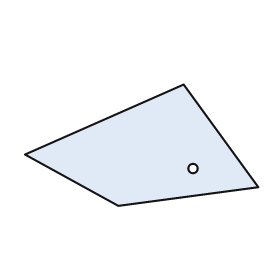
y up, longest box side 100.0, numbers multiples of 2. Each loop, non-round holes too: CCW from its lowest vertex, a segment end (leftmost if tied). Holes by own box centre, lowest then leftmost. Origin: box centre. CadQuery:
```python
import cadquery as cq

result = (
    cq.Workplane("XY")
    .moveTo(-10.0, -26.0)
    .lineTo(50.0, -18.0)
    .lineTo(18.0, 26.0)
    .lineTo(-50.0, -4.0)
    .close()
    .moveTo(22.0, -10.0)
    .circle(2.0)
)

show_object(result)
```